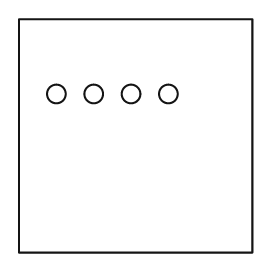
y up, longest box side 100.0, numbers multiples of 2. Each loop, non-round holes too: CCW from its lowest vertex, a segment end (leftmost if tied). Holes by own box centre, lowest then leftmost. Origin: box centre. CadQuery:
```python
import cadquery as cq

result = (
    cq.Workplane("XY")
    .moveTo(-50.0, -50.0)
    .lineTo(50.0, -50.0)
    .lineTo(50.0, 50.0)
    .lineTo(-50.0, 50.0)
    .close()
    .moveTo(-34.0, 18.0)
    .circle(4.0)
    .moveTo(-18.0, 18.0)
    .circle(4.0)
    .moveTo(-2.0, 18.0)
    .circle(4.0)
    .moveTo(14.0, 18.0)
    .circle(4.0)
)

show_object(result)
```